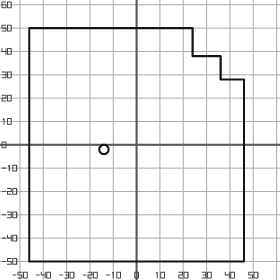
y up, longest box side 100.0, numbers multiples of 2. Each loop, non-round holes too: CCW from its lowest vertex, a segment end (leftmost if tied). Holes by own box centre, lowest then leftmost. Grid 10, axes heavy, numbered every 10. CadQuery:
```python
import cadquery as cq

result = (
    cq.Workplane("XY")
    .moveTo(-46.0, -50.0)
    .lineTo(46.0, -50.0)
    .lineTo(46.0, 28.0)
    .lineTo(36.0, 28.0)
    .lineTo(36.0, 38.0)
    .lineTo(24.0, 38.0)
    .lineTo(24.0, 50.0)
    .lineTo(-46.0, 50.0)
    .close()
    .moveTo(-14.0, -2.0)
    .circle(2.0)
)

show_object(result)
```